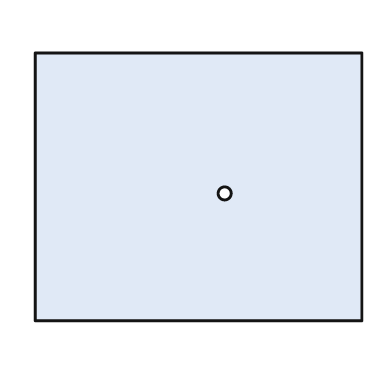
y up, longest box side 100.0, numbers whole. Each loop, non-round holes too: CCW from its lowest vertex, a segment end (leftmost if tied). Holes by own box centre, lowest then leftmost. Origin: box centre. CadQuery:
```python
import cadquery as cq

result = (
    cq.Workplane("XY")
    .moveTo(-50.0, -41.0)
    .lineTo(50.0, -41.0)
    .lineTo(50.0, 41.0)
    .lineTo(-50.0, 41.0)
    .close()
    .moveTo(8.0, -2.0)
    .circle(2.0)
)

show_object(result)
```